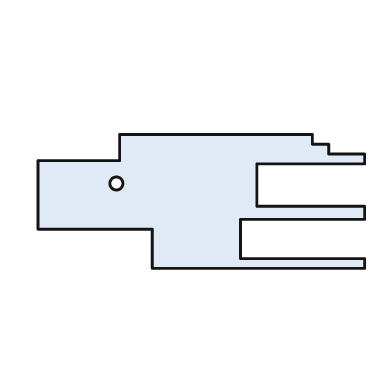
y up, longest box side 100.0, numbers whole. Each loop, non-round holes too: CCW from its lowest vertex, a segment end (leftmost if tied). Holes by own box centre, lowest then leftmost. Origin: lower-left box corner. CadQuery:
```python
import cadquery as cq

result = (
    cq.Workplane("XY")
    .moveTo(35.0, 0.0)
    .lineTo(100.0, 0.0)
    .lineTo(100.0, 3.0)
    .lineTo(62.0, 3.0)
    .lineTo(62.0, 15.0)
    .lineTo(100.0, 15.0)
    .lineTo(100.0, 19.0)
    .lineTo(67.0, 19.0)
    .lineTo(67.0, 32.0)
    .lineTo(100.0, 32.0)
    .lineTo(100.0, 35.0)
    .lineTo(89.0, 35.0)
    .lineTo(89.0, 38.0)
    .lineTo(84.0, 38.0)
    .lineTo(84.0, 41.0)
    .lineTo(25.0, 41.0)
    .lineTo(25.0, 33.0)
    .lineTo(0.0, 33.0)
    .lineTo(0.0, 12.0)
    .lineTo(35.0, 12.0)
    .close()
    .moveTo(24.0, 26.0)
    .circle(2.0)
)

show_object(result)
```